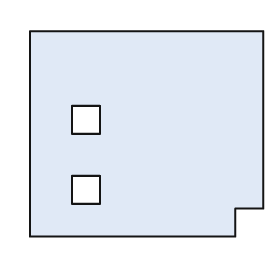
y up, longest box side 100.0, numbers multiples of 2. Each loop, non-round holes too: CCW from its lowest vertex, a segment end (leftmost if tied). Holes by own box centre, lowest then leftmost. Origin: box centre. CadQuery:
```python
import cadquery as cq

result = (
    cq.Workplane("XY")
    .moveTo(-50.0, -44.0)
    .lineTo(38.0, -44.0)
    .lineTo(38.0, -32.0)
    .lineTo(50.0, -32.0)
    .lineTo(50.0, 44.0)
    .lineTo(-50.0, 44.0)
    .close()
    .moveTo(-32.0, -30.0)
    .lineTo(-20.0, -30.0)
    .lineTo(-20.0, -18.0)
    .lineTo(-32.0, -18.0)
    .close()
    .moveTo(-32.0, 0.0)
    .lineTo(-20.0, 0.0)
    .lineTo(-20.0, 12.0)
    .lineTo(-32.0, 12.0)
    .close()
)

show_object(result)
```